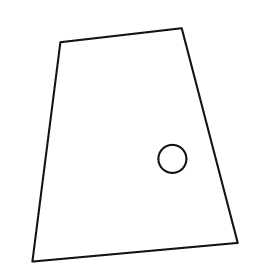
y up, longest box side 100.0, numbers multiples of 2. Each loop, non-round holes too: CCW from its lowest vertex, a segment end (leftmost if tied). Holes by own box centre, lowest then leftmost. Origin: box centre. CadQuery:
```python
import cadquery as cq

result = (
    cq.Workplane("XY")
    .moveTo(-44.0, -50.0)
    .lineTo(44.0, -42.0)
    .lineTo(20.0, 50.0)
    .lineTo(-32.0, 44.0)
    .close()
    .moveTo(16.0, -6.0)
    .circle(6.0)
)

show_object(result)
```